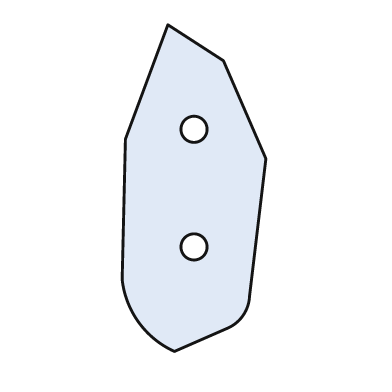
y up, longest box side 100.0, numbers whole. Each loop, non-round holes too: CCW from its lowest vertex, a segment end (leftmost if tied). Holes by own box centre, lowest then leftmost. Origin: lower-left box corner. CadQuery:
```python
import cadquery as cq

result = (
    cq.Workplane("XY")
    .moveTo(16.0, 0.0)
    .lineTo(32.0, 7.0)
    .threePointArc((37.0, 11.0), (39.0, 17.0))
    .lineTo(44.0, 59.0)
    .lineTo(31.0, 89.0)
    .lineTo(14.0, 100.0)
    .lineTo(1.0, 65.0)
    .lineTo(0.0, 22.0)
    .threePointArc((5.0, 9.0), (16.0, 0.0))
    .close()
    .moveTo(22.0, 32.0)
    .circle(4.0)
    .moveTo(22.0, 68.0)
    .circle(4.0)
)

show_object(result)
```